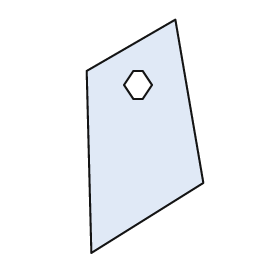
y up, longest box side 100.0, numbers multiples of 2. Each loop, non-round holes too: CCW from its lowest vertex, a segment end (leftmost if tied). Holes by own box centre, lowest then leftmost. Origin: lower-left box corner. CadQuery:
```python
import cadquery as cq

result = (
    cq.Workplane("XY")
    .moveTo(2.0, 0.0)
    .lineTo(50.0, 30.0)
    .lineTo(38.0, 100.0)
    .lineTo(0.0, 78.0)
    .close()
    .moveTo(20.0, 66.0)
    .lineTo(24.0, 66.0)
    .lineTo(28.0, 72.0)
    .lineTo(24.0, 78.0)
    .lineTo(20.0, 78.0)
    .lineTo(16.0, 72.0)
    .close()
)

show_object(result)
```